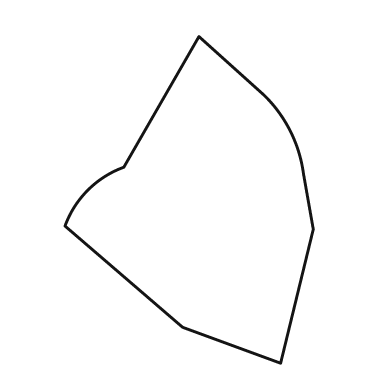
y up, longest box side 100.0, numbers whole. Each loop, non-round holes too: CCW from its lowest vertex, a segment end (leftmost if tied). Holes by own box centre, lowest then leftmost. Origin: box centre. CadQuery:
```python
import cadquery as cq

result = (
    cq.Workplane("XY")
    .moveTo(28.0, -50.0)
    .lineTo(38.0, -9.0)
    .lineTo(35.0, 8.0)
    .threePointArc((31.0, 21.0), (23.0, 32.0))
    .lineTo(3.0, 50.0)
    .lineTo(-20.0, 10.0)
    .threePointArc((-31.0, 3.0), (-38.0, -8.0))
    .lineTo(-2.0, -39.0)
    .close()
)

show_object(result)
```